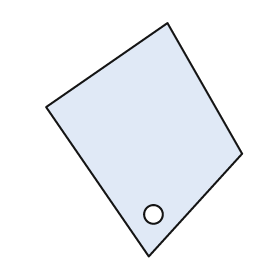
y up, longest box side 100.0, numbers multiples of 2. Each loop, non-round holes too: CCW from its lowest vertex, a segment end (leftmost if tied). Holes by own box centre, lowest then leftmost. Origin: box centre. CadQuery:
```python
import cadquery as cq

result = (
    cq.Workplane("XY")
    .moveTo(2.0, -50.0)
    .lineTo(42.0, -6.0)
    .lineTo(10.0, 50.0)
    .lineTo(-42.0, 14.0)
    .close()
    .moveTo(4.0, -32.0)
    .circle(4.0)
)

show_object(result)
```